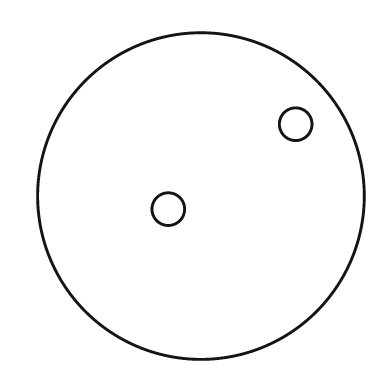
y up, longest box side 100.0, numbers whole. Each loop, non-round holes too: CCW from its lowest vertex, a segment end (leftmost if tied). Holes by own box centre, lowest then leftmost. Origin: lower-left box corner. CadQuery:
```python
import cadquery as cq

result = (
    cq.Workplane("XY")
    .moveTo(50.0, 50.0)
    .circle(50.0)
    .moveTo(40.0, 46.0)
    .circle(5.0)
    .moveTo(79.0, 72.0)
    .circle(5.0)
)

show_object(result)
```